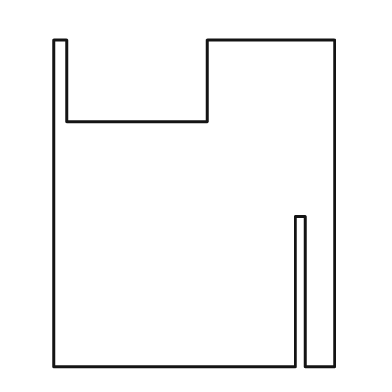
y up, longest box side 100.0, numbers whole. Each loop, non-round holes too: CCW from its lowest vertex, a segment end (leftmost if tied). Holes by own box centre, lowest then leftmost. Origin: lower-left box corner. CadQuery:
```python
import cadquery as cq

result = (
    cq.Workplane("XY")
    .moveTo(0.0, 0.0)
    .lineTo(74.0, 0.0)
    .lineTo(74.0, 46.0)
    .lineTo(77.0, 46.0)
    .lineTo(77.0, 0.0)
    .lineTo(86.0, 0.0)
    .lineTo(86.0, 100.0)
    .lineTo(47.0, 100.0)
    .lineTo(47.0, 75.0)
    .lineTo(4.0, 75.0)
    .lineTo(4.0, 100.0)
    .lineTo(0.0, 100.0)
    .close()
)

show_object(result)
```